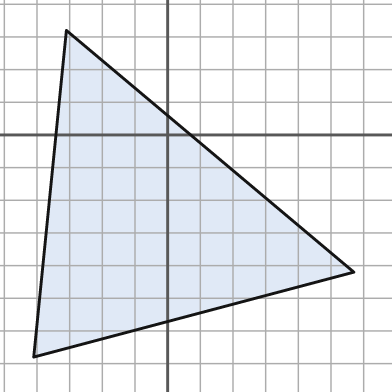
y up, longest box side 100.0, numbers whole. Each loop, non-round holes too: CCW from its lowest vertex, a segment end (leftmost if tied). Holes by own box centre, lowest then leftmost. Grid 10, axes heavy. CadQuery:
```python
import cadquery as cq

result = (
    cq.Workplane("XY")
    .moveTo(-41.0, -68.0)
    .lineTo(57.0, -42.0)
    .lineTo(-31.0, 32.0)
    .close()
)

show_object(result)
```